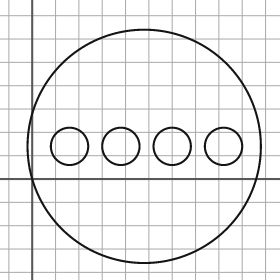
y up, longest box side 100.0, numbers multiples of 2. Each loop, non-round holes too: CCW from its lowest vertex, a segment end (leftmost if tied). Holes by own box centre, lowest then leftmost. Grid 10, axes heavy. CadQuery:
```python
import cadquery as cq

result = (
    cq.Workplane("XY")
    .moveTo(48.0, 14.0)
    .circle(50.0)
    .moveTo(16.0, 14.0)
    .circle(8.0)
    .moveTo(38.0, 14.0)
    .circle(8.0)
    .moveTo(60.0, 14.0)
    .circle(8.0)
    .moveTo(82.0, 14.0)
    .circle(8.0)
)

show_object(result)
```